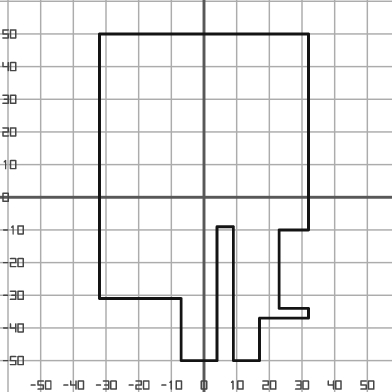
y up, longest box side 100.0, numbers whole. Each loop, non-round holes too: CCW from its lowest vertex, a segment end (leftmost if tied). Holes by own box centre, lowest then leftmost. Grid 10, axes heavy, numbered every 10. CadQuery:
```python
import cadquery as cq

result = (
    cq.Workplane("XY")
    .moveTo(-7.0, -50.0)
    .lineTo(4.0, -50.0)
    .lineTo(4.0, -9.0)
    .lineTo(9.0, -9.0)
    .lineTo(9.0, -50.0)
    .lineTo(17.0, -50.0)
    .lineTo(17.0, -37.0)
    .lineTo(32.0, -37.0)
    .lineTo(32.0, -34.0)
    .lineTo(23.0, -34.0)
    .lineTo(23.0, -10.0)
    .lineTo(32.0, -10.0)
    .lineTo(32.0, 50.0)
    .lineTo(-32.0, 50.0)
    .lineTo(-32.0, -31.0)
    .lineTo(-7.0, -31.0)
    .close()
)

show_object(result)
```